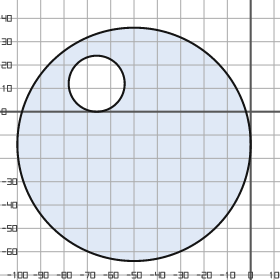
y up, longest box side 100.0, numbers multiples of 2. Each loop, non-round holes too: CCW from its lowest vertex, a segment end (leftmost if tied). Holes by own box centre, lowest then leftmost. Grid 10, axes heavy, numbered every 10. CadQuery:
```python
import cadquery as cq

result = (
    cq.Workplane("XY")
    .moveTo(-50.0, -14.0)
    .circle(50.0)
    .moveTo(-66.0, 12.0)
    .circle(12.0)
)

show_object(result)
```